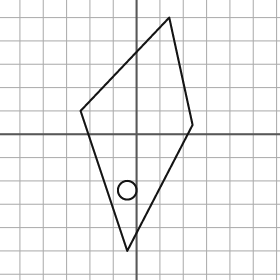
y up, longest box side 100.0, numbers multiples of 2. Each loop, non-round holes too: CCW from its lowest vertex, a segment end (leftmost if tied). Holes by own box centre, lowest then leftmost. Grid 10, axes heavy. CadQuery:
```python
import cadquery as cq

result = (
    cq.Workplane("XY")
    .moveTo(-4.0, -50.0)
    .lineTo(24.0, 4.0)
    .lineTo(14.0, 50.0)
    .lineTo(-24.0, 10.0)
    .close()
    .moveTo(-4.0, -24.0)
    .circle(4.0)
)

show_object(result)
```